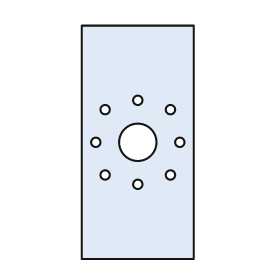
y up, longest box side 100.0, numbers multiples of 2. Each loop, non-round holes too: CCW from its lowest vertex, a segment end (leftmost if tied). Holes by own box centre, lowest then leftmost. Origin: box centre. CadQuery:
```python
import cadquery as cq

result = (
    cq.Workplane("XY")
    .moveTo(-24.0, -50.0)
    .lineTo(24.0, -50.0)
    .lineTo(24.0, 50.0)
    .lineTo(-24.0, 50.0)
    .close()
    .moveTo(0.0, -18.0)
    .circle(2.0)
    .moveTo(-14.0, -14.0)
    .circle(2.0)
    .moveTo(14.0, -14.0)
    .circle(2.0)
    .moveTo(-18.0, 0.0)
    .circle(2.0)
    .moveTo(0.0, 0.0)
    .circle(8.0)
    .moveTo(18.0, 0.0)
    .circle(2.0)
    .moveTo(-14.0, 14.0)
    .circle(2.0)
    .moveTo(14.0, 14.0)
    .circle(2.0)
    .moveTo(0.0, 18.0)
    .circle(2.0)
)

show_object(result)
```